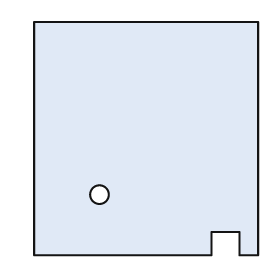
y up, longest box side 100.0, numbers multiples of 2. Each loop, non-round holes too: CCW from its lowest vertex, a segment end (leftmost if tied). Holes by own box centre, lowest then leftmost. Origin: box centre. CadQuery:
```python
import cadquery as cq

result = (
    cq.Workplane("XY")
    .moveTo(-48.0, -50.0)
    .lineTo(28.0, -50.0)
    .lineTo(28.0, -40.0)
    .lineTo(40.0, -40.0)
    .lineTo(40.0, -50.0)
    .lineTo(48.0, -50.0)
    .lineTo(48.0, 50.0)
    .lineTo(-48.0, 50.0)
    .close()
    .moveTo(-20.0, -24.0)
    .circle(4.0)
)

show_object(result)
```